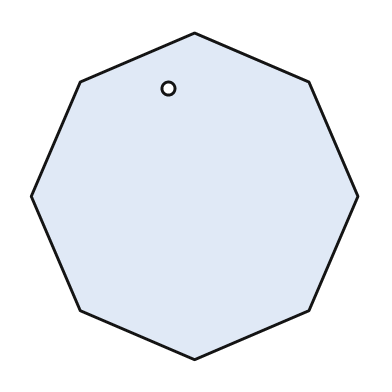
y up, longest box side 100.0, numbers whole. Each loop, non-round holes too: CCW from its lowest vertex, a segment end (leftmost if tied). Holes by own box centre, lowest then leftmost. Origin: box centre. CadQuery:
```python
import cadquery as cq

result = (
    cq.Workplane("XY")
    .moveTo(0.0, -50.0)
    .lineTo(35.0, -35.0)
    .lineTo(50.0, 0.0)
    .lineTo(35.0, 35.0)
    .lineTo(0.0, 50.0)
    .lineTo(-35.0, 35.0)
    .lineTo(-50.0, 0.0)
    .lineTo(-35.0, -35.0)
    .close()
    .moveTo(-8.0, 33.0)
    .circle(2.0)
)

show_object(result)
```